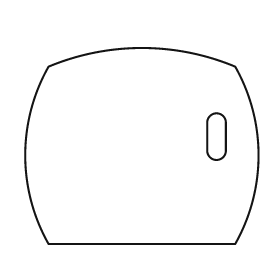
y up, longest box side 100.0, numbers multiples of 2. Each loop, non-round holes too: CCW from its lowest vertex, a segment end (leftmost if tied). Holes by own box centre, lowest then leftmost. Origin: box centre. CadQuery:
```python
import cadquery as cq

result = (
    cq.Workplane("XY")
    .moveTo(-40.0, -42.0)
    .lineTo(40.0, -42.0)
    .threePointArc((50.0, -4.0), (40.0, 34.0))
    .threePointArc((0.0, 42.0), (-40.0, 34.0))
    .threePointArc((-50.0, -4.0), (-40.0, -42.0))
    .close()
    .moveTo(28.0, -2.0)
    .threePointArc((32.0, -6.0), (36.0, -2.0))
    .lineTo(36.0, 10.0)
    .threePointArc((32.0, 14.0), (28.0, 10.0))
    .close()
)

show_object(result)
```